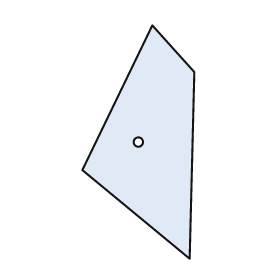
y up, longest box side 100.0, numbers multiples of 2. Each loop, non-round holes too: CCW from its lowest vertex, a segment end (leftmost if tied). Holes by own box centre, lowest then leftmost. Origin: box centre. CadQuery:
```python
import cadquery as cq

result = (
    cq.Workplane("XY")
    .moveTo(22.0, -50.0)
    .lineTo(24.0, 30.0)
    .lineTo(6.0, 50.0)
    .lineTo(-24.0, -12.0)
    .close()
    .moveTo(0.0, 0.0)
    .circle(2.0)
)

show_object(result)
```